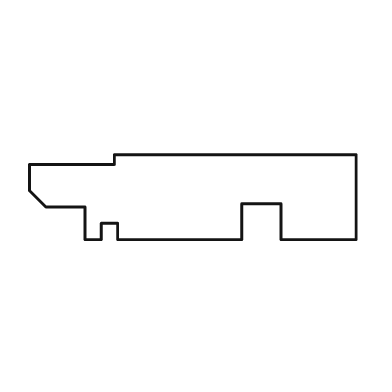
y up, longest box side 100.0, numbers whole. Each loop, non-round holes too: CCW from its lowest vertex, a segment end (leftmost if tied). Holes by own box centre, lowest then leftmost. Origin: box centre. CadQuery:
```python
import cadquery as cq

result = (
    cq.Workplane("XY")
    .moveTo(-33.0, -13.0)
    .lineTo(-28.0, -13.0)
    .lineTo(-28.0, -8.0)
    .lineTo(-23.0, -8.0)
    .lineTo(-23.0, -13.0)
    .lineTo(15.0, -13.0)
    .lineTo(15.0, -2.0)
    .lineTo(27.0, -2.0)
    .lineTo(27.0, -13.0)
    .lineTo(50.0, -13.0)
    .lineTo(50.0, 13.0)
    .lineTo(-24.0, 13.0)
    .lineTo(-24.0, 10.0)
    .lineTo(-50.0, 10.0)
    .lineTo(-50.0, 2.0)
    .lineTo(-45.0, -3.0)
    .lineTo(-33.0, -3.0)
    .close()
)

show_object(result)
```